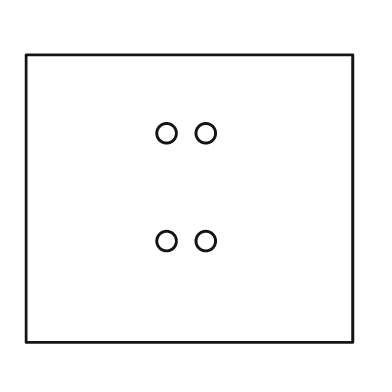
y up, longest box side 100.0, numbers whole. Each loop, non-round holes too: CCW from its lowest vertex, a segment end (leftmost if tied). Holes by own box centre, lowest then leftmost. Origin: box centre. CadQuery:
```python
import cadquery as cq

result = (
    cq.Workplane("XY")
    .moveTo(-50.0, -44.0)
    .lineTo(50.0, -44.0)
    .lineTo(50.0, 44.0)
    .lineTo(-50.0, 44.0)
    .close()
    .moveTo(-7.0, -13.0)
    .circle(3.0)
    .moveTo(5.0, -13.0)
    .circle(3.0)
    .moveTo(-7.0, 20.0)
    .circle(3.0)
    .moveTo(5.0, 20.0)
    .circle(3.0)
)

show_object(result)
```